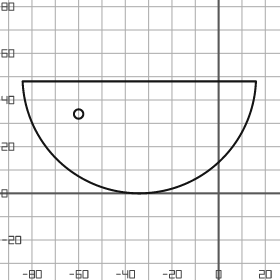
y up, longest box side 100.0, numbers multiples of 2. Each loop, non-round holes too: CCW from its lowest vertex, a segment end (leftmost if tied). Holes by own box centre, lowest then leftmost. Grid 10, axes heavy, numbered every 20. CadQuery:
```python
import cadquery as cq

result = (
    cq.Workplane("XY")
    .moveTo(-84.0, 48.0)
    .threePointArc((-34.0, 0.0), (16.0, 48.0))
    .close()
    .moveTo(-60.0, 34.0)
    .circle(2.0)
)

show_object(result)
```